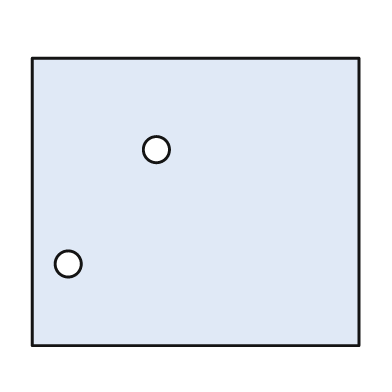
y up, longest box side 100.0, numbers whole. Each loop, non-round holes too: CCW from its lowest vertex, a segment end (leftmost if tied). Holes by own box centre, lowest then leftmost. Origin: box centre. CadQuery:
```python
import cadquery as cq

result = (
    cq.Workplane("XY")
    .moveTo(-50.0, -44.0)
    .lineTo(50.0, -44.0)
    .lineTo(50.0, 44.0)
    .lineTo(-50.0, 44.0)
    .close()
    .moveTo(-39.0, -19.0)
    .circle(4.0)
    .moveTo(-12.0, 16.0)
    .circle(4.0)
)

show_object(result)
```